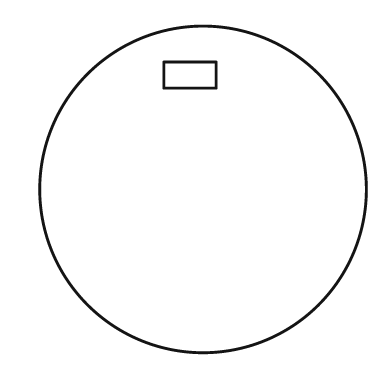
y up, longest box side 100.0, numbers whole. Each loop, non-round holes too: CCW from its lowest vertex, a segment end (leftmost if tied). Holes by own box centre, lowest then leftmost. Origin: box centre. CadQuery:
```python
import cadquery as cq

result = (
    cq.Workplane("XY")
    .moveTo(0.0, 0.0)
    .circle(50.0)
    .moveTo(-12.0, 31.0)
    .lineTo(4.0, 31.0)
    .lineTo(4.0, 39.0)
    .lineTo(-12.0, 39.0)
    .close()
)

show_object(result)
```